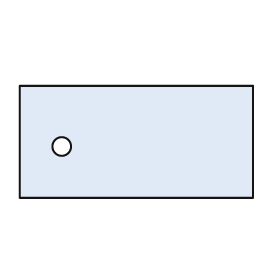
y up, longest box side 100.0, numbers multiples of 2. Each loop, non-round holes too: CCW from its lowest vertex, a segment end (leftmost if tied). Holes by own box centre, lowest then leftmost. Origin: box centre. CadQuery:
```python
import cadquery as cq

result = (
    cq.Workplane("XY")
    .moveTo(-50.0, -24.0)
    .lineTo(50.0, -24.0)
    .lineTo(50.0, 24.0)
    .lineTo(-50.0, 24.0)
    .close()
    .moveTo(-32.0, -2.0)
    .circle(4.0)
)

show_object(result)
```